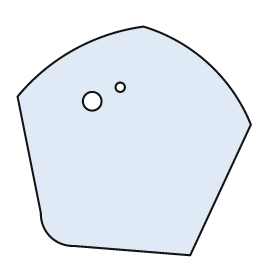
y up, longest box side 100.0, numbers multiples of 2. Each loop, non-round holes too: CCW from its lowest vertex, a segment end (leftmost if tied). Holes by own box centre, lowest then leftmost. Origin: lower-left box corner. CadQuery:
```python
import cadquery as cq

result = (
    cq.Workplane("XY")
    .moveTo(74.0, 0.0)
    .lineTo(100.0, 56.0)
    .threePointArc((82.0, 82.0), (54.0, 98.0))
    .threePointArc((24.0, 88.0), (0.0, 68.0))
    .lineTo(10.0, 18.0)
    .threePointArc((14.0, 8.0), (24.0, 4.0))
    .close()
    .moveTo(32.0, 66.0)
    .circle(4.0)
    .moveTo(44.0, 72.0)
    .circle(2.0)
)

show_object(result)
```